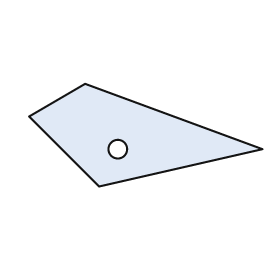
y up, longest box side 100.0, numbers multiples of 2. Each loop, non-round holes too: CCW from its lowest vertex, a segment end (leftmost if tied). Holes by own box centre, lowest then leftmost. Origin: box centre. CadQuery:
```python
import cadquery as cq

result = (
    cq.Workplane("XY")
    .moveTo(-20.0, -22.0)
    .lineTo(50.0, -6.0)
    .lineTo(-26.0, 22.0)
    .lineTo(-50.0, 8.0)
    .close()
    .moveTo(-12.0, -6.0)
    .circle(4.0)
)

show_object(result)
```